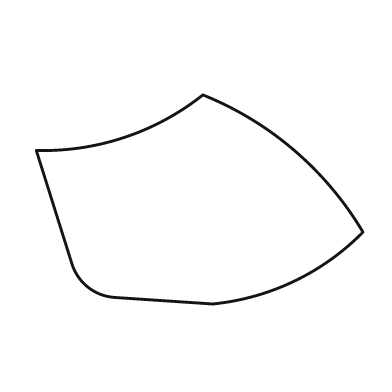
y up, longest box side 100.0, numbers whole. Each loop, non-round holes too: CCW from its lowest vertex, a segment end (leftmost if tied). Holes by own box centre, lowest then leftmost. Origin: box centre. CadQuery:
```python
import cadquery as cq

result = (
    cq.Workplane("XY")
    .moveTo(4.0, -32.0)
    .threePointArc((29.0, -25.0), (50.0, -10.0))
    .threePointArc((29.0, 15.0), (1.0, 32.0))
    .threePointArc((-23.0, 19.0), (-50.0, 15.0))
    .lineTo(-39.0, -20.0)
    .threePointArc((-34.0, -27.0), (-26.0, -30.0))
    .close()
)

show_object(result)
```